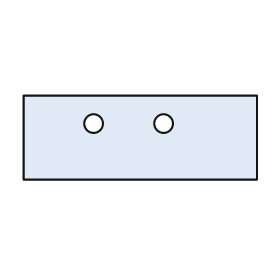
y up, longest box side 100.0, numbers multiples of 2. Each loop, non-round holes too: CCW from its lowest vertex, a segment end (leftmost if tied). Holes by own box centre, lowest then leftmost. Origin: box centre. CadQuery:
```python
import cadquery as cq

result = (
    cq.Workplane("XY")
    .moveTo(-50.0, -18.0)
    .lineTo(50.0, -18.0)
    .lineTo(50.0, 18.0)
    .lineTo(-50.0, 18.0)
    .close()
    .moveTo(-20.0, 6.0)
    .circle(4.0)
    .moveTo(10.0, 6.0)
    .circle(4.0)
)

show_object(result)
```